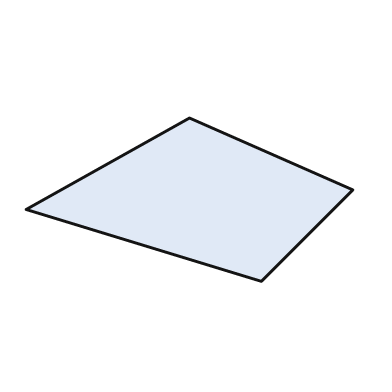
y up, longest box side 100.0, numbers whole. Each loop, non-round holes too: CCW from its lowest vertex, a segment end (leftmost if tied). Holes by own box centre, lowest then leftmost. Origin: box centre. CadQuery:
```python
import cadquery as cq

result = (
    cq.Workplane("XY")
    .moveTo(22.0, -25.0)
    .lineTo(50.0, 3.0)
    .lineTo(0.0, 25.0)
    .lineTo(-50.0, -3.0)
    .close()
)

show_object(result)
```